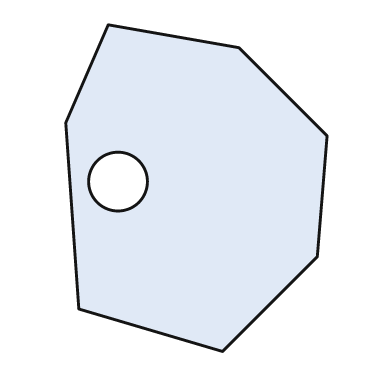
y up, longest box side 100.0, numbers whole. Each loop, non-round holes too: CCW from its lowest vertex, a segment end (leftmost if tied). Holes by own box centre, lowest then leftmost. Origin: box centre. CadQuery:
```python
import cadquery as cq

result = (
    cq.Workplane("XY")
    .moveTo(8.0, -50.0)
    .lineTo(37.0, -21.0)
    .lineTo(40.0, 16.0)
    .lineTo(13.0, 43.0)
    .lineTo(-27.0, 50.0)
    .lineTo(-40.0, 20.0)
    .lineTo(-36.0, -37.0)
    .close()
    .moveTo(-24.0, 2.0)
    .circle(9.0)
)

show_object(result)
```